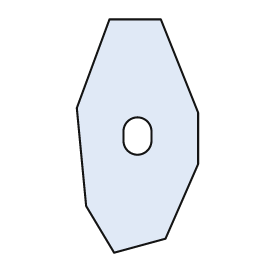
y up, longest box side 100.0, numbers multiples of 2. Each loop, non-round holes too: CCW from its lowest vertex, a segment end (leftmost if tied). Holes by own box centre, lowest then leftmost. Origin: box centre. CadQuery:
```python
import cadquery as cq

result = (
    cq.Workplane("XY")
    .moveTo(-10.0, -50.0)
    .lineTo(12.0, -44.0)
    .lineTo(26.0, -12.0)
    .lineTo(26.0, 10.0)
    .lineTo(10.0, 50.0)
    .lineTo(-12.0, 50.0)
    .lineTo(-26.0, 12.0)
    .lineTo(-22.0, -30.0)
    .close()
    .moveTo(-6.0, -2.0)
    .threePointArc((0.0, -8.0), (6.0, -2.0))
    .lineTo(6.0, 2.0)
    .threePointArc((0.0, 8.0), (-6.0, 2.0))
    .close()
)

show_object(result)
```